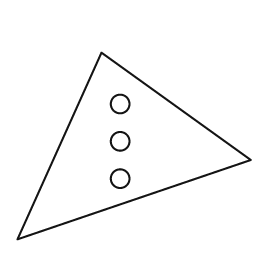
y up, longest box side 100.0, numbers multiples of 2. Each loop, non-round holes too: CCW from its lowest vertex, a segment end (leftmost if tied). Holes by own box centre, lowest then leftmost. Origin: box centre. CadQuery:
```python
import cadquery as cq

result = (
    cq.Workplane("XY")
    .moveTo(-50.0, -40.0)
    .lineTo(50.0, -6.0)
    .lineTo(-14.0, 40.0)
    .close()
    .moveTo(-6.0, -14.0)
    .circle(4.0)
    .moveTo(-6.0, 2.0)
    .circle(4.0)
    .moveTo(-6.0, 18.0)
    .circle(4.0)
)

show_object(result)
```